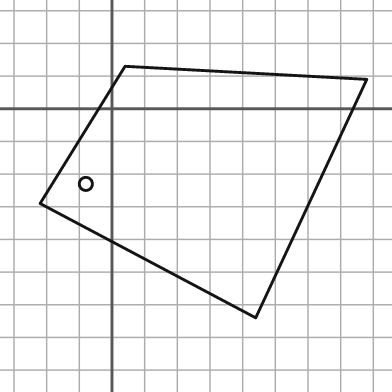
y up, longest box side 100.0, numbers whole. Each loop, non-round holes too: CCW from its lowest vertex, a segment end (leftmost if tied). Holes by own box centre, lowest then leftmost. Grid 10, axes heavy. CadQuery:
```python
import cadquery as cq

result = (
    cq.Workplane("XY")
    .moveTo(44.0, -64.0)
    .lineTo(78.0, 9.0)
    .lineTo(4.0, 13.0)
    .lineTo(-22.0, -29.0)
    .close()
    .moveTo(-8.0, -23.0)
    .circle(2.0)
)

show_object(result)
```